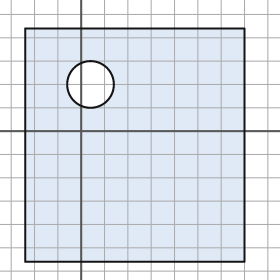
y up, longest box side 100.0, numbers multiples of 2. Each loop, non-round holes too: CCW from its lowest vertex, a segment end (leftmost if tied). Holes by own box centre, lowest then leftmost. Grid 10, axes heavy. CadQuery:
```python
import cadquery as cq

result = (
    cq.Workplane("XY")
    .moveTo(-24.0, -56.0)
    .lineTo(70.0, -56.0)
    .lineTo(70.0, 44.0)
    .lineTo(-24.0, 44.0)
    .close()
    .moveTo(4.0, 20.0)
    .circle(10.0)
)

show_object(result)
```